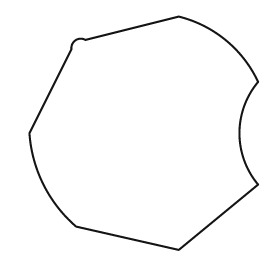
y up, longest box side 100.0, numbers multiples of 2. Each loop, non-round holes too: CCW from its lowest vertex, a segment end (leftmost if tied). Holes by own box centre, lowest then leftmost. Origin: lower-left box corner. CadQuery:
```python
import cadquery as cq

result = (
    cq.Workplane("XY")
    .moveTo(64.0, 0.0)
    .lineTo(98.0, 28.0)
    .threePointArc((90.0, 50.0), (98.0, 72.0))
    .threePointArc((84.0, 90.0), (64.0, 100.0))
    .lineTo(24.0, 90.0)
    .threePointArc((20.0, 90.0), (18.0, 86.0))
    .lineTo(0.0, 50.0)
    .threePointArc((6.0, 28.0), (20.0, 10.0))
    .close()
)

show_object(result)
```